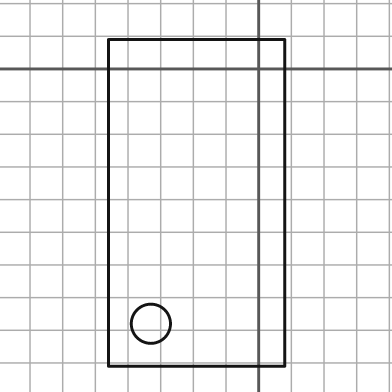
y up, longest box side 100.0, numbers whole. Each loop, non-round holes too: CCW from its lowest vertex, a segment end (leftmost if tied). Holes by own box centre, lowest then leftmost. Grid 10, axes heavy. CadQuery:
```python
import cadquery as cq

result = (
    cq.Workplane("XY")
    .moveTo(-46.0, -91.0)
    .lineTo(8.0, -91.0)
    .lineTo(8.0, 9.0)
    .lineTo(-46.0, 9.0)
    .close()
    .moveTo(-33.0, -78.0)
    .circle(6.0)
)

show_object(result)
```